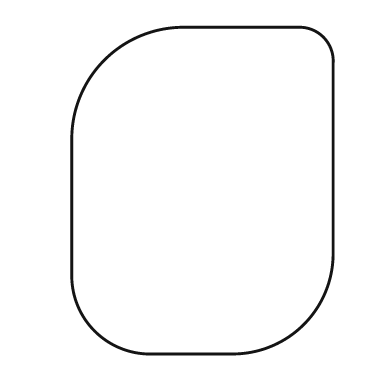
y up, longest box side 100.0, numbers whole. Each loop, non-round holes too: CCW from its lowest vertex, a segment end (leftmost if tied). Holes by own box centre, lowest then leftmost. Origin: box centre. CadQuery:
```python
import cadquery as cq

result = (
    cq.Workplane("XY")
    .moveTo(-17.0, -50.0)
    .lineTo(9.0, -50.0)
    .threePointArc((31.0, -41.0), (40.0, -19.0))
    .lineTo(40.0, 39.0)
    .threePointArc((37.0, 47.0), (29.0, 50.0))
    .lineTo(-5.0, 50.0)
    .threePointArc((-30.0, 40.0), (-40.0, 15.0))
    .lineTo(-40.0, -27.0)
    .threePointArc((-33.0, -43.0), (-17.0, -50.0))
    .close()
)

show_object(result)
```